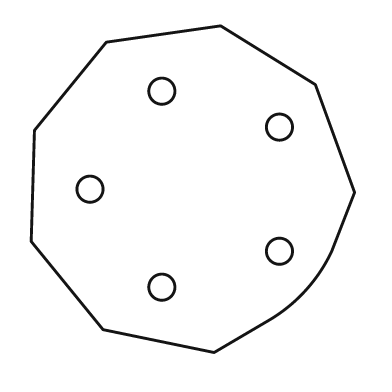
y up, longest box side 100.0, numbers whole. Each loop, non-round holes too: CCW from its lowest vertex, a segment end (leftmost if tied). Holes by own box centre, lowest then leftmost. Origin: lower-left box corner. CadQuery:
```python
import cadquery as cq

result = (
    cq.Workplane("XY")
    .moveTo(56.0, 0.0)
    .lineTo(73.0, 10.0)
    .threePointArc((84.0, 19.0), (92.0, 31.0))
    .lineTo(99.0, 49.0)
    .lineTo(87.0, 82.0)
    .lineTo(58.0, 100.0)
    .lineTo(23.0, 95.0)
    .lineTo(1.0, 68.0)
    .lineTo(0.0, 34.0)
    .lineTo(22.0, 7.0)
    .close()
    .moveTo(40.0, 20.0)
    .circle(4.0)
    .moveTo(76.0, 31.0)
    .circle(4.0)
    .moveTo(18.0, 50.0)
    .circle(4.0)
    .moveTo(76.0, 69.0)
    .circle(4.0)
    .moveTo(40.0, 80.0)
    .circle(4.0)
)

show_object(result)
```